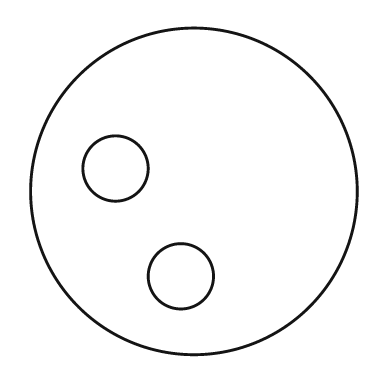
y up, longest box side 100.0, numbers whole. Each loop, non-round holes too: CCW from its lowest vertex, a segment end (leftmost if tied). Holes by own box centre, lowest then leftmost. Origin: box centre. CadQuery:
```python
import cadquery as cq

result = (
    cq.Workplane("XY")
    .moveTo(0.0, 0.0)
    .circle(50.0)
    .moveTo(-4.0, -26.0)
    .circle(10.0)
    .moveTo(-24.0, 7.0)
    .circle(10.0)
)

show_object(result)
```